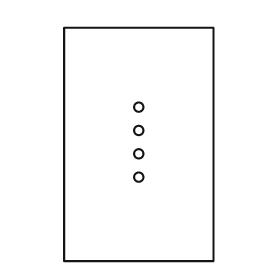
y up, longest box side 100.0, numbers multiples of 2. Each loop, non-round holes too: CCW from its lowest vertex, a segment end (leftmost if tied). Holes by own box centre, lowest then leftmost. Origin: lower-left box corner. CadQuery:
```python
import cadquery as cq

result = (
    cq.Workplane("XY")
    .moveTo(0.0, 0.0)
    .lineTo(64.0, 0.0)
    .lineTo(64.0, 100.0)
    .lineTo(0.0, 100.0)
    .close()
    .moveTo(32.0, 36.0)
    .circle(2.0)
    .moveTo(32.0, 46.0)
    .circle(2.0)
    .moveTo(32.0, 56.0)
    .circle(2.0)
    .moveTo(32.0, 66.0)
    .circle(2.0)
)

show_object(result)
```